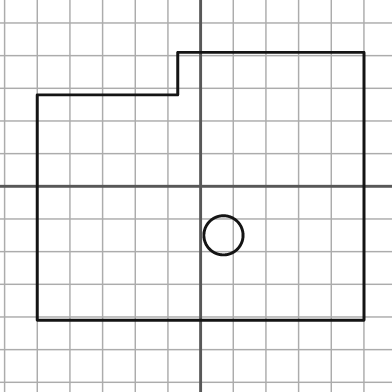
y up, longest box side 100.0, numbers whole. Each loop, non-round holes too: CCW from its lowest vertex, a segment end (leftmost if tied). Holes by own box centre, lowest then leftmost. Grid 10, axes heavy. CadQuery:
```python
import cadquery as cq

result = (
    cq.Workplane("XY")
    .moveTo(-50.0, -41.0)
    .lineTo(50.0, -41.0)
    .lineTo(50.0, 41.0)
    .lineTo(-7.0, 41.0)
    .lineTo(-7.0, 28.0)
    .lineTo(-50.0, 28.0)
    .close()
    .moveTo(7.0, -15.0)
    .circle(6.0)
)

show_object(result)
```